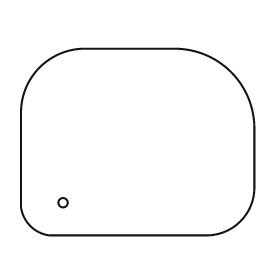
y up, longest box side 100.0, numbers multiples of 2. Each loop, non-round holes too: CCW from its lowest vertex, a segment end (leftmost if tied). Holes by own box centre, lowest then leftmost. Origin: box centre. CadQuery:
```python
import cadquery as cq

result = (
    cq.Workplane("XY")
    .moveTo(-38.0, -40.0)
    .lineTo(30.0, -40.0)
    .threePointArc((44.0, -34.0), (50.0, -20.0))
    .lineTo(50.0, 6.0)
    .threePointArc((40.0, 30.0), (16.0, 40.0))
    .lineTo(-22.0, 40.0)
    .threePointArc((-42.0, 32.0), (-50.0, 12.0))
    .lineTo(-50.0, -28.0)
    .threePointArc((-46.0, -36.0), (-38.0, -40.0))
    .close()
    .moveTo(-32.0, -26.0)
    .circle(2.0)
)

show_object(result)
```